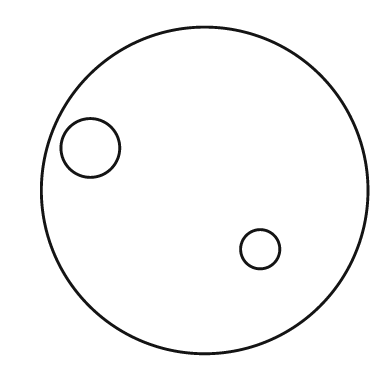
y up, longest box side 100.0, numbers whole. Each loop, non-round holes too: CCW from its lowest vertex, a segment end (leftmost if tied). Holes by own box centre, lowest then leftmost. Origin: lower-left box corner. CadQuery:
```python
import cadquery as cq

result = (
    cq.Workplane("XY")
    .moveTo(50.0, 50.0)
    .circle(50.0)
    .moveTo(67.0, 32.0)
    .circle(6.0)
    .moveTo(15.0, 63.0)
    .circle(9.0)
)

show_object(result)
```